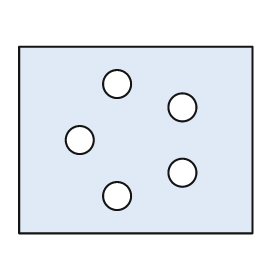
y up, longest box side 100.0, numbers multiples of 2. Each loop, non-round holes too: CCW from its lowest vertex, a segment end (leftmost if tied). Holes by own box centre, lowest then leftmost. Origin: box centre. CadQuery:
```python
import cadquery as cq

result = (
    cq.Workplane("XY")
    .moveTo(-50.0, -40.0)
    .lineTo(50.0, -40.0)
    .lineTo(50.0, 40.0)
    .lineTo(-50.0, 40.0)
    .close()
    .moveTo(-8.0, -24.0)
    .circle(6.0)
    .moveTo(20.0, -14.0)
    .circle(6.0)
    .moveTo(-24.0, 0.0)
    .circle(6.0)
    .moveTo(20.0, 14.0)
    .circle(6.0)
    .moveTo(-8.0, 24.0)
    .circle(6.0)
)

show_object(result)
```